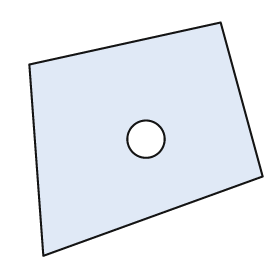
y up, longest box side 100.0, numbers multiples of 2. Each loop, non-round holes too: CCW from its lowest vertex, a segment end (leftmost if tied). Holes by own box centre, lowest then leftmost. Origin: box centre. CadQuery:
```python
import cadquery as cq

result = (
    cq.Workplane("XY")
    .moveTo(-44.0, -50.0)
    .lineTo(50.0, -16.0)
    .lineTo(32.0, 50.0)
    .lineTo(-50.0, 32.0)
    .close()
    .moveTo(0.0, 0.0)
    .circle(8.0)
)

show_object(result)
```